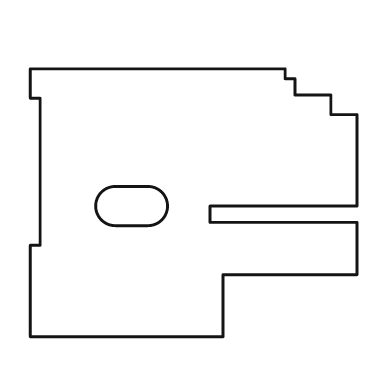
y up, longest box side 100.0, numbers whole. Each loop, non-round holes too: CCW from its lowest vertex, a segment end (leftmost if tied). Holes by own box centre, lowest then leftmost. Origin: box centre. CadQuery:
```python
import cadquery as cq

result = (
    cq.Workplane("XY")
    .moveTo(-50.0, -41.0)
    .lineTo(9.0, -41.0)
    .lineTo(9.0, -22.0)
    .lineTo(50.0, -22.0)
    .lineTo(50.0, -6.0)
    .lineTo(5.0, -6.0)
    .lineTo(5.0, -1.0)
    .lineTo(50.0, -1.0)
    .lineTo(50.0, 27.0)
    .lineTo(42.0, 27.0)
    .lineTo(42.0, 33.0)
    .lineTo(31.0, 33.0)
    .lineTo(31.0, 38.0)
    .lineTo(28.0, 38.0)
    .lineTo(28.0, 41.0)
    .lineTo(-50.0, 41.0)
    .lineTo(-50.0, 32.0)
    .lineTo(-47.0, 32.0)
    .lineTo(-47.0, -13.0)
    .lineTo(-50.0, -13.0)
    .close()
    .moveTo(-24.0, -7.0)
    .lineTo(-14.0, -7.0)
    .threePointArc((-8.0, -1.0), (-14.0, 5.0))
    .lineTo(-24.0, 5.0)
    .threePointArc((-30.0, -1.0), (-24.0, -7.0))
    .close()
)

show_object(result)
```